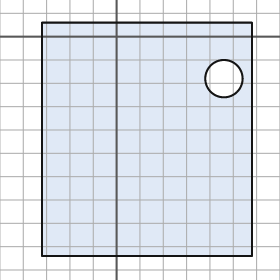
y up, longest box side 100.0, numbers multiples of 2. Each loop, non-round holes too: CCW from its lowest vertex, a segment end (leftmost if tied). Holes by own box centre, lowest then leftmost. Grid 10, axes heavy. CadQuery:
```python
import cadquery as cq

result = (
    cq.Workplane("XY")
    .moveTo(-32.0, -94.0)
    .lineTo(58.0, -94.0)
    .lineTo(58.0, 6.0)
    .lineTo(-32.0, 6.0)
    .close()
    .moveTo(46.0, -18.0)
    .circle(8.0)
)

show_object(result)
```